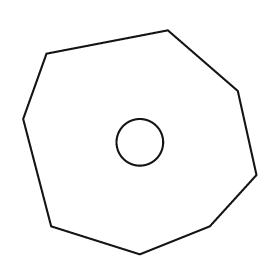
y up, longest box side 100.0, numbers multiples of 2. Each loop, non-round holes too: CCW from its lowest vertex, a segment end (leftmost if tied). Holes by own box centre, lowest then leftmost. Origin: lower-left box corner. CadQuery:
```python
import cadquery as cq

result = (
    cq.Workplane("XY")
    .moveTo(50.0, 0.0)
    .lineTo(80.0, 12.0)
    .lineTo(100.0, 34.0)
    .lineTo(92.0, 70.0)
    .lineTo(62.0, 96.0)
    .lineTo(10.0, 86.0)
    .lineTo(0.0, 58.0)
    .lineTo(12.0, 12.0)
    .close()
    .moveTo(50.0, 48.0)
    .circle(10.0)
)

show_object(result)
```